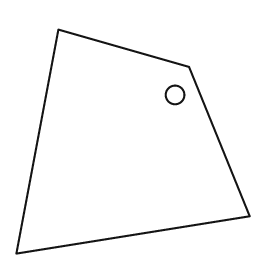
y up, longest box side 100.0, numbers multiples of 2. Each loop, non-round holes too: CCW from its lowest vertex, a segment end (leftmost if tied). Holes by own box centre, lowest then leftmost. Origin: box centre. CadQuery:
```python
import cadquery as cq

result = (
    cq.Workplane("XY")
    .moveTo(-50.0, -48.0)
    .lineTo(50.0, -32.0)
    .lineTo(24.0, 32.0)
    .lineTo(-32.0, 48.0)
    .close()
    .moveTo(18.0, 20.0)
    .circle(4.0)
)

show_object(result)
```